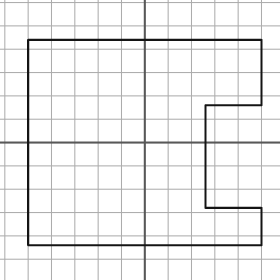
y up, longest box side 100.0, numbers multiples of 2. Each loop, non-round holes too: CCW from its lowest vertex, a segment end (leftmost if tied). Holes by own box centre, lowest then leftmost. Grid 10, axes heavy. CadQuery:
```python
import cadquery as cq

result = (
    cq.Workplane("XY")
    .moveTo(-50.0, -44.0)
    .lineTo(50.0, -44.0)
    .lineTo(50.0, -28.0)
    .lineTo(26.0, -28.0)
    .lineTo(26.0, 16.0)
    .lineTo(50.0, 16.0)
    .lineTo(50.0, 44.0)
    .lineTo(-50.0, 44.0)
    .close()
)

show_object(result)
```